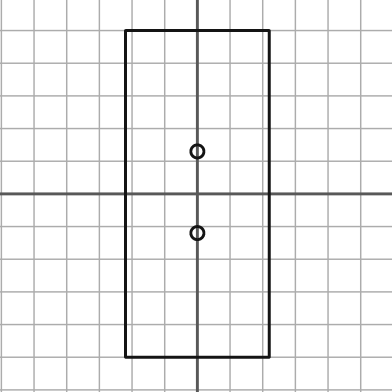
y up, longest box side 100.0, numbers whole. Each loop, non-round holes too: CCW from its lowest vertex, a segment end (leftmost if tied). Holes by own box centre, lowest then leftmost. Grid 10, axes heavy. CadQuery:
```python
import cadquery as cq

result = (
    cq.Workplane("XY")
    .moveTo(-22.0, -50.0)
    .lineTo(22.0, -50.0)
    .lineTo(22.0, 50.0)
    .lineTo(-22.0, 50.0)
    .close()
    .moveTo(0.0, -12.0)
    .circle(2.0)
    .moveTo(0.0, 13.0)
    .circle(2.0)
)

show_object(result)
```